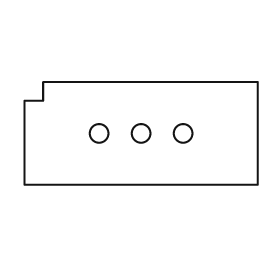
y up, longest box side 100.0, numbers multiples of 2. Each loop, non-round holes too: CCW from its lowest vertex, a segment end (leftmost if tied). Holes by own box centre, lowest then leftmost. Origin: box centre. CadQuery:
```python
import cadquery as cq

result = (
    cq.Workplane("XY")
    .moveTo(-50.0, -22.0)
    .lineTo(50.0, -22.0)
    .lineTo(50.0, 22.0)
    .lineTo(-42.0, 22.0)
    .lineTo(-42.0, 14.0)
    .lineTo(-50.0, 14.0)
    .close()
    .moveTo(-18.0, 0.0)
    .circle(4.0)
    .moveTo(0.0, 0.0)
    .circle(4.0)
    .moveTo(18.0, 0.0)
    .circle(4.0)
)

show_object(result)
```